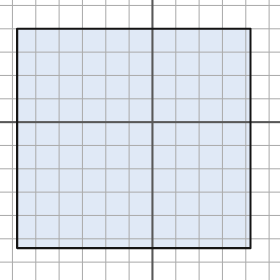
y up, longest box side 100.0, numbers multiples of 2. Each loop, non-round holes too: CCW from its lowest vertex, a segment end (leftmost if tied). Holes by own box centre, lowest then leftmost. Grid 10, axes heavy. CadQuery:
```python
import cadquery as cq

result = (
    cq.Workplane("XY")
    .moveTo(-58.0, -54.0)
    .lineTo(42.0, -54.0)
    .lineTo(42.0, 40.0)
    .lineTo(-58.0, 40.0)
    .close()
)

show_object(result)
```